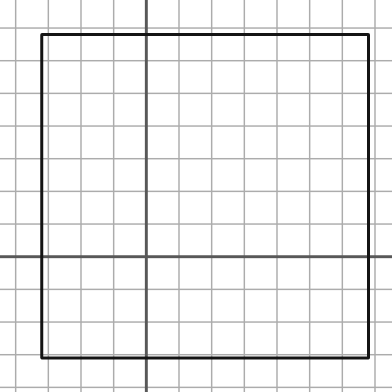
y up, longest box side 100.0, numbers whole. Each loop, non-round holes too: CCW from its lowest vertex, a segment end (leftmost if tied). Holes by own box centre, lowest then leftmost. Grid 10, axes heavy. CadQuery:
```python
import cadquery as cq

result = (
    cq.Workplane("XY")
    .moveTo(-32.0, -31.0)
    .lineTo(68.0, -31.0)
    .lineTo(68.0, 68.0)
    .lineTo(-32.0, 68.0)
    .close()
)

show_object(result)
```